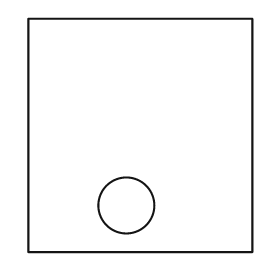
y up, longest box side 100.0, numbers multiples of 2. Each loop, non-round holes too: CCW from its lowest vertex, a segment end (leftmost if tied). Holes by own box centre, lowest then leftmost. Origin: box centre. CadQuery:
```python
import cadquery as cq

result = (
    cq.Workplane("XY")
    .moveTo(-48.0, -50.0)
    .lineTo(48.0, -50.0)
    .lineTo(48.0, 50.0)
    .lineTo(-48.0, 50.0)
    .close()
    .moveTo(-6.0, -30.0)
    .circle(12.0)
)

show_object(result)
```